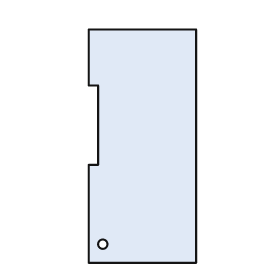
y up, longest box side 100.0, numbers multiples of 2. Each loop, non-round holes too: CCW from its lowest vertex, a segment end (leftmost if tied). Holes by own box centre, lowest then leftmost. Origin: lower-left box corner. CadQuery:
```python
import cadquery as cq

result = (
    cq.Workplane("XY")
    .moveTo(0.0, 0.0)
    .lineTo(46.0, 0.0)
    .lineTo(46.0, 100.0)
    .lineTo(0.0, 100.0)
    .lineTo(0.0, 76.0)
    .lineTo(4.0, 76.0)
    .lineTo(4.0, 42.0)
    .lineTo(0.0, 42.0)
    .close()
    .moveTo(6.0, 8.0)
    .circle(2.0)
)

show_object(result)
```